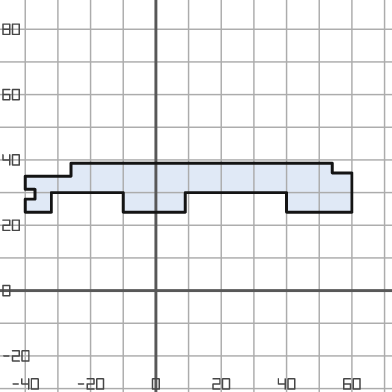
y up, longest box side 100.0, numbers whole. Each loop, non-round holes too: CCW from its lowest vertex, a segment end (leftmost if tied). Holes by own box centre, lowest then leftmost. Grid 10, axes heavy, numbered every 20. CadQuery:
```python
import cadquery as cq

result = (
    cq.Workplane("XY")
    .moveTo(-40.0, 24.0)
    .lineTo(-32.0, 24.0)
    .lineTo(-32.0, 30.0)
    .lineTo(-10.0, 30.0)
    .lineTo(-10.0, 24.0)
    .lineTo(9.0, 24.0)
    .lineTo(9.0, 30.0)
    .lineTo(40.0, 30.0)
    .lineTo(40.0, 24.0)
    .lineTo(60.0, 24.0)
    .lineTo(60.0, 36.0)
    .lineTo(54.0, 36.0)
    .lineTo(54.0, 39.0)
    .lineTo(-26.0, 39.0)
    .lineTo(-26.0, 35.0)
    .lineTo(-40.0, 35.0)
    .lineTo(-40.0, 31.0)
    .lineTo(-37.0, 31.0)
    .lineTo(-37.0, 28.0)
    .lineTo(-40.0, 28.0)
    .close()
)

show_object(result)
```